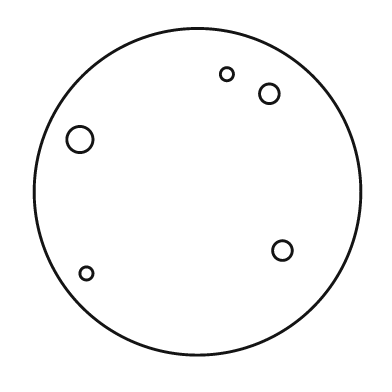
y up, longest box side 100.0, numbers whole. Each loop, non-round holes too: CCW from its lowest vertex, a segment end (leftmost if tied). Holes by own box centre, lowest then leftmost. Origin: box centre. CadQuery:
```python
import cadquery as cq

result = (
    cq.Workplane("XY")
    .moveTo(0.0, 0.0)
    .circle(50.0)
    .moveTo(-34.0, -25.0)
    .circle(2.0)
    .moveTo(26.0, -18.0)
    .circle(3.0)
    .moveTo(-36.0, 16.0)
    .circle(4.0)
    .moveTo(22.0, 30.0)
    .circle(3.0)
    .moveTo(9.0, 36.0)
    .circle(2.0)
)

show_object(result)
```